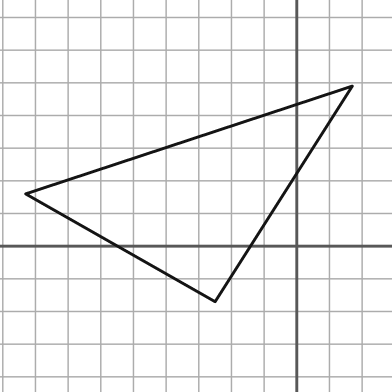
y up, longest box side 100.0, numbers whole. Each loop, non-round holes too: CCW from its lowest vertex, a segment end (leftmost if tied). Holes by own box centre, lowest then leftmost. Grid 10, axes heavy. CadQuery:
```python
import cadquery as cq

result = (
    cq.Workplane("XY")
    .moveTo(-25.0, -17.0)
    .lineTo(17.0, 49.0)
    .lineTo(-83.0, 16.0)
    .close()
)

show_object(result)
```